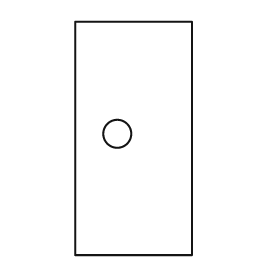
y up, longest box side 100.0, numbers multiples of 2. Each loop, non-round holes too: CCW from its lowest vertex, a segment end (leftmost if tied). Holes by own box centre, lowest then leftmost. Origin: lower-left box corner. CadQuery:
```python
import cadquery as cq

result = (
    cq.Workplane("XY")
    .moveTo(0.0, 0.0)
    .lineTo(50.0, 0.0)
    .lineTo(50.0, 100.0)
    .lineTo(0.0, 100.0)
    .close()
    .moveTo(18.0, 52.0)
    .circle(6.0)
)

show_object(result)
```